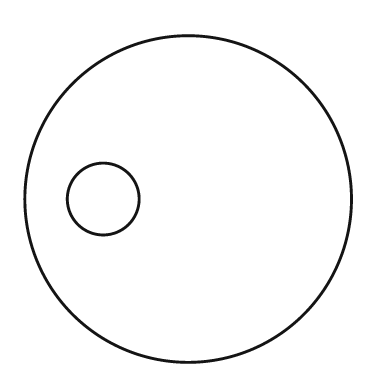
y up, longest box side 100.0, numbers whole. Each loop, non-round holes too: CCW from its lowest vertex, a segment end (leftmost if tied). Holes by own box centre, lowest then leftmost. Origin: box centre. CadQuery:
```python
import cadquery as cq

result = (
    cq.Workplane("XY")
    .moveTo(0.0, 0.0)
    .circle(50.0)
    .moveTo(-26.0, 0.0)
    .circle(11.0)
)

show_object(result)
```